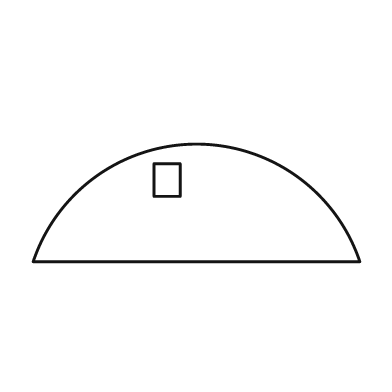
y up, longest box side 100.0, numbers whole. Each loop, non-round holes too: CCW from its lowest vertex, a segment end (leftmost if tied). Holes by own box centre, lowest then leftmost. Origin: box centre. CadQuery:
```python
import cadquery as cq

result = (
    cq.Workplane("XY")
    .moveTo(-50.0, -18.0)
    .lineTo(50.0, -18.0)
    .threePointArc((0.0, 18.0), (-50.0, -18.0))
    .close()
    .moveTo(-13.0, 2.0)
    .lineTo(-5.0, 2.0)
    .lineTo(-5.0, 12.0)
    .lineTo(-13.0, 12.0)
    .close()
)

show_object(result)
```